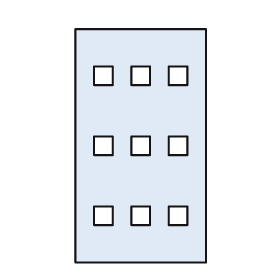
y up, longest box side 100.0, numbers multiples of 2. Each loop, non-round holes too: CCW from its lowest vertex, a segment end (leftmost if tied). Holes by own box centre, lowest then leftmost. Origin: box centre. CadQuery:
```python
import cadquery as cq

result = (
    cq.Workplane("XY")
    .moveTo(-28.0, -50.0)
    .lineTo(28.0, -50.0)
    .lineTo(28.0, 50.0)
    .lineTo(-28.0, 50.0)
    .close()
    .moveTo(-20.0, -34.0)
    .lineTo(-12.0, -34.0)
    .lineTo(-12.0, -26.0)
    .lineTo(-20.0, -26.0)
    .close()
    .moveTo(-4.0, -34.0)
    .lineTo(4.0, -34.0)
    .lineTo(4.0, -26.0)
    .lineTo(-4.0, -26.0)
    .close()
    .moveTo(12.0, -34.0)
    .lineTo(20.0, -34.0)
    .lineTo(20.0, -26.0)
    .lineTo(12.0, -26.0)
    .close()
    .moveTo(-20.0, -4.0)
    .lineTo(-12.0, -4.0)
    .lineTo(-12.0, 4.0)
    .lineTo(-20.0, 4.0)
    .close()
    .moveTo(-4.0, -4.0)
    .lineTo(4.0, -4.0)
    .lineTo(4.0, 4.0)
    .lineTo(-4.0, 4.0)
    .close()
    .moveTo(12.0, -4.0)
    .lineTo(20.0, -4.0)
    .lineTo(20.0, 4.0)
    .lineTo(12.0, 4.0)
    .close()
    .moveTo(-20.0, 26.0)
    .lineTo(-12.0, 26.0)
    .lineTo(-12.0, 34.0)
    .lineTo(-20.0, 34.0)
    .close()
    .moveTo(-4.0, 26.0)
    .lineTo(4.0, 26.0)
    .lineTo(4.0, 34.0)
    .lineTo(-4.0, 34.0)
    .close()
    .moveTo(12.0, 26.0)
    .lineTo(20.0, 26.0)
    .lineTo(20.0, 34.0)
    .lineTo(12.0, 34.0)
    .close()
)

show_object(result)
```